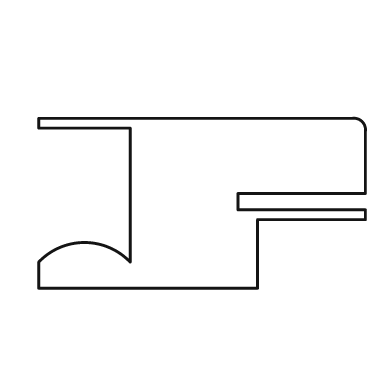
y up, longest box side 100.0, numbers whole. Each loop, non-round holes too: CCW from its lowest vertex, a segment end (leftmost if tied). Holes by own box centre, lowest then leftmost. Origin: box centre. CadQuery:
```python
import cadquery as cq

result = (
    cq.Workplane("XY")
    .moveTo(-50.0, -26.0)
    .lineTo(17.0, -26.0)
    .lineTo(17.0, -5.0)
    .lineTo(50.0, -5.0)
    .lineTo(50.0, -2.0)
    .lineTo(11.0, -2.0)
    .lineTo(11.0, 3.0)
    .lineTo(50.0, 3.0)
    .lineTo(50.0, 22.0)
    .threePointArc((49.0, 25.0), (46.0, 26.0))
    .lineTo(-50.0, 26.0)
    .lineTo(-50.0, 23.0)
    .lineTo(-22.0, 23.0)
    .lineTo(-22.0, -18.0)
    .threePointArc((-36.0, -12.0), (-50.0, -18.0))
    .close()
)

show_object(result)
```